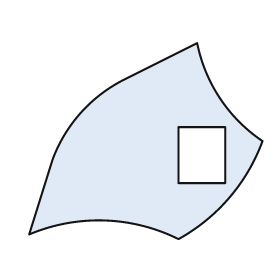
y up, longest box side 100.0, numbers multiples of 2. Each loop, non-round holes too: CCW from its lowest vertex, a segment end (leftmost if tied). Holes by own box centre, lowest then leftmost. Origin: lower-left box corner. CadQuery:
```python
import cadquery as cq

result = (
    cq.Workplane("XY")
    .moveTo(64.0, 0.0)
    .threePointArc((86.0, 18.0), (100.0, 42.0))
    .threePointArc((82.0, 60.0), (72.0, 84.0))
    .lineTo(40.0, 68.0)
    .threePointArc((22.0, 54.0), (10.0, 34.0))
    .lineTo(0.0, 2.0)
    .threePointArc((32.0, 8.0), (64.0, 0.0))
    .close()
    .moveTo(64.0, 24.0)
    .lineTo(84.0, 24.0)
    .lineTo(84.0, 48.0)
    .lineTo(64.0, 48.0)
    .close()
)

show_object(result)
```